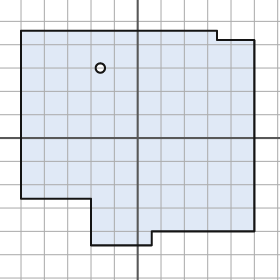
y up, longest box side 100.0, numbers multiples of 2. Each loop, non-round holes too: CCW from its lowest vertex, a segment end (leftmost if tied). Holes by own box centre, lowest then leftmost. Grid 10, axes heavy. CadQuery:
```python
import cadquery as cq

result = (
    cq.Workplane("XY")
    .moveTo(-20.0, -46.0)
    .lineTo(6.0, -46.0)
    .lineTo(6.0, -40.0)
    .lineTo(50.0, -40.0)
    .lineTo(50.0, 42.0)
    .lineTo(34.0, 42.0)
    .lineTo(34.0, 46.0)
    .lineTo(-50.0, 46.0)
    .lineTo(-50.0, -26.0)
    .lineTo(-20.0, -26.0)
    .close()
    .moveTo(-16.0, 30.0)
    .circle(2.0)
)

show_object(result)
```